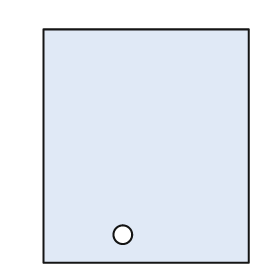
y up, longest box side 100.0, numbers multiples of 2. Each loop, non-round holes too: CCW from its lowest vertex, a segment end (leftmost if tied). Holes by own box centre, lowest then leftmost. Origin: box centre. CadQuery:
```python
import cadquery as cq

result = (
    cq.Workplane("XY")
    .moveTo(-44.0, -50.0)
    .lineTo(44.0, -50.0)
    .lineTo(44.0, 50.0)
    .lineTo(-44.0, 50.0)
    .close()
    .moveTo(-10.0, -38.0)
    .circle(4.0)
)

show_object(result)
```